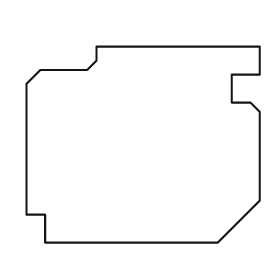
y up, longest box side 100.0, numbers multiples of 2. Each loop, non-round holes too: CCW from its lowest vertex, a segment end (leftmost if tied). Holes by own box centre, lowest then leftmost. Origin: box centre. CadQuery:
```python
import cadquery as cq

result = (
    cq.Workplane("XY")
    .moveTo(-42.0, -42.0)
    .lineTo(32.0, -42.0)
    .lineTo(50.0, -24.0)
    .lineTo(50.0, 14.0)
    .lineTo(46.0, 18.0)
    .lineTo(38.0, 18.0)
    .lineTo(38.0, 30.0)
    .lineTo(50.0, 30.0)
    .lineTo(50.0, 42.0)
    .lineTo(-20.0, 42.0)
    .lineTo(-20.0, 36.0)
    .lineTo(-24.0, 32.0)
    .lineTo(-44.0, 32.0)
    .lineTo(-50.0, 26.0)
    .lineTo(-50.0, -30.0)
    .lineTo(-42.0, -30.0)
    .close()
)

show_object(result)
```